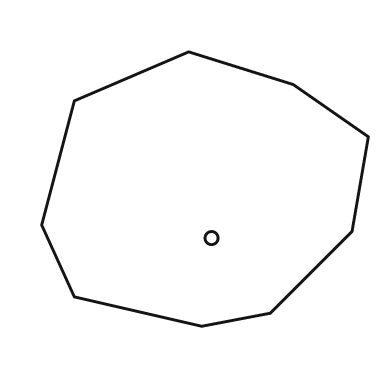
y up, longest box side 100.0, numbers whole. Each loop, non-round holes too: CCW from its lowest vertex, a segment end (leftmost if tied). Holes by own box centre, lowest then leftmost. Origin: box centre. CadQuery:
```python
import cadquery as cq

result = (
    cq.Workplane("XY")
    .moveTo(-1.0, -42.0)
    .lineTo(20.0, -38.0)
    .lineTo(45.0, -13.0)
    .lineTo(50.0, 16.0)
    .lineTo(27.0, 32.0)
    .lineTo(-5.0, 42.0)
    .lineTo(-40.0, 27.0)
    .lineTo(-50.0, -11.0)
    .lineTo(-40.0, -33.0)
    .close()
    .moveTo(2.0, -15.0)
    .circle(2.0)
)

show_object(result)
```